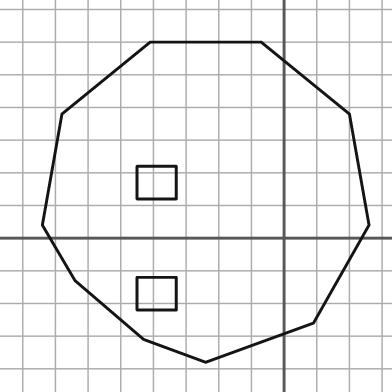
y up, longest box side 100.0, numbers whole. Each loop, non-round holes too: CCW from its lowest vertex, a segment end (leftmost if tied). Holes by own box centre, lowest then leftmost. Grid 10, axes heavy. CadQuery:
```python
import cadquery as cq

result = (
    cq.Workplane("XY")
    .moveTo(-24.0, -38.0)
    .lineTo(9.0, -26.0)
    .lineTo(26.0, 4.0)
    .lineTo(20.0, 38.0)
    .lineTo(-7.0, 60.0)
    .lineTo(-41.0, 60.0)
    .lineTo(-68.0, 38.0)
    .lineTo(-74.0, 4.0)
    .lineTo(-64.0, -13.0)
    .lineTo(-43.0, -31.0)
    .close()
    .moveTo(-45.0, -22.0)
    .lineTo(-33.0, -22.0)
    .lineTo(-33.0, -12.0)
    .lineTo(-45.0, -12.0)
    .close()
    .moveTo(-45.0, 12.0)
    .lineTo(-33.0, 12.0)
    .lineTo(-33.0, 22.0)
    .lineTo(-45.0, 22.0)
    .close()
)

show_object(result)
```